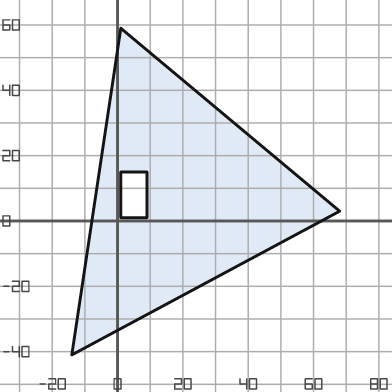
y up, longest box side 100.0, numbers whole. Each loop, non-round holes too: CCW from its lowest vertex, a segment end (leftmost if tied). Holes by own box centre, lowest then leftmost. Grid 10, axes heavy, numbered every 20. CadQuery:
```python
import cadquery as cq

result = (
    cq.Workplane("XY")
    .moveTo(-14.0, -41.0)
    .lineTo(68.0, 3.0)
    .lineTo(1.0, 59.0)
    .close()
    .moveTo(1.0, 1.0)
    .lineTo(9.0, 1.0)
    .lineTo(9.0, 15.0)
    .lineTo(1.0, 15.0)
    .close()
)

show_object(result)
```